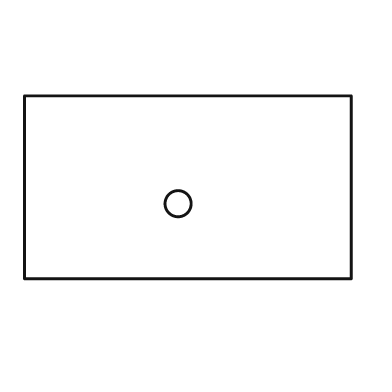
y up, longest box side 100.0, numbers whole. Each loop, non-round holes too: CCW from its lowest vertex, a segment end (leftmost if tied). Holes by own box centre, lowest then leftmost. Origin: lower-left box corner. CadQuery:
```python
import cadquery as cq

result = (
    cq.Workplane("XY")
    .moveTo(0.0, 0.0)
    .lineTo(100.0, 0.0)
    .lineTo(100.0, 56.0)
    .lineTo(0.0, 56.0)
    .close()
    .moveTo(47.0, 23.0)
    .circle(4.0)
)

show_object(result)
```